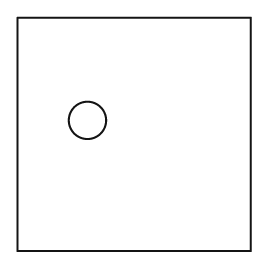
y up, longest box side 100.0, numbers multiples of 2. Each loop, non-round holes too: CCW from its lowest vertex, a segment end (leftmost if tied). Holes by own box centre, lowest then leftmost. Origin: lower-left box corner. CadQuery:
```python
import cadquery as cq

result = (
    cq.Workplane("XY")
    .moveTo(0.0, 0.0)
    .lineTo(100.0, 0.0)
    .lineTo(100.0, 100.0)
    .lineTo(0.0, 100.0)
    .close()
    .moveTo(30.0, 56.0)
    .circle(8.0)
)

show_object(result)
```